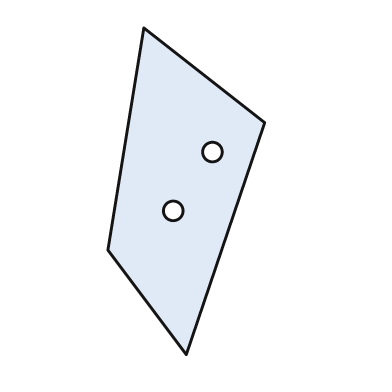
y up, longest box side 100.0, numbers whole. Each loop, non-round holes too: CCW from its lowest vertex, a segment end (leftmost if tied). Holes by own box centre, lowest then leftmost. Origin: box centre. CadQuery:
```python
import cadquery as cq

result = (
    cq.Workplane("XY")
    .moveTo(0.0, -50.0)
    .lineTo(24.0, 21.0)
    .lineTo(-13.0, 50.0)
    .lineTo(-24.0, -18.0)
    .close()
    .moveTo(-4.0, -6.0)
    .circle(3.0)
    .moveTo(8.0, 12.0)
    .circle(3.0)
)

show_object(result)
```